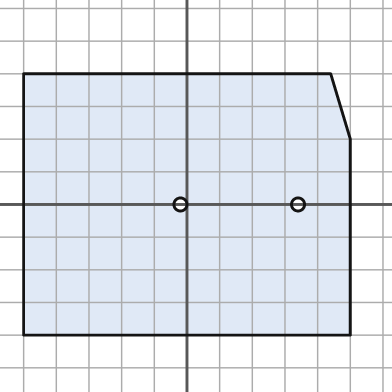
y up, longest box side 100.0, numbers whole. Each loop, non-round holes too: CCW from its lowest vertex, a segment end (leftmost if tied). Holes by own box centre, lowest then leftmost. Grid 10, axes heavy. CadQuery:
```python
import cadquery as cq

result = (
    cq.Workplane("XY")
    .moveTo(-50.0, -40.0)
    .lineTo(50.0, -40.0)
    .lineTo(50.0, 20.0)
    .lineTo(44.0, 40.0)
    .lineTo(-50.0, 40.0)
    .close()
    .moveTo(-2.0, 0.0)
    .circle(2.0)
    .moveTo(34.0, 0.0)
    .circle(2.0)
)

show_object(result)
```